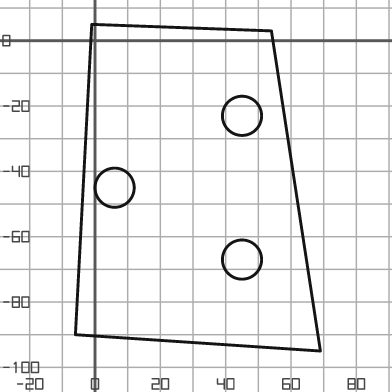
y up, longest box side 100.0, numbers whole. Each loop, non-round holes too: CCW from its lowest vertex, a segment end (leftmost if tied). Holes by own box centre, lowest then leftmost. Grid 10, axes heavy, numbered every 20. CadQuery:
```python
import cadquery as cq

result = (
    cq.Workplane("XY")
    .moveTo(69.0, -95.0)
    .lineTo(54.0, 3.0)
    .lineTo(-1.0, 5.0)
    .lineTo(-6.0, -90.0)
    .close()
    .moveTo(45.0, -67.0)
    .circle(6.0)
    .moveTo(6.0, -45.0)
    .circle(6.0)
    .moveTo(45.0, -23.0)
    .circle(6.0)
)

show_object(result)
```